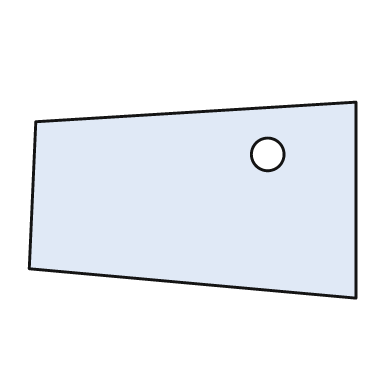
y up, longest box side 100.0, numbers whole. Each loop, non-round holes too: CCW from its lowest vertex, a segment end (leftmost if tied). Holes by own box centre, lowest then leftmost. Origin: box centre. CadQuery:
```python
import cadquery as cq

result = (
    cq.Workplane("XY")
    .moveTo(50.0, -30.0)
    .lineTo(50.0, 30.0)
    .lineTo(-48.0, 24.0)
    .lineTo(-50.0, -21.0)
    .close()
    .moveTo(23.0, 14.0)
    .circle(5.0)
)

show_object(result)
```